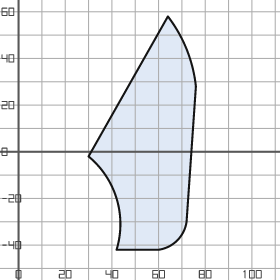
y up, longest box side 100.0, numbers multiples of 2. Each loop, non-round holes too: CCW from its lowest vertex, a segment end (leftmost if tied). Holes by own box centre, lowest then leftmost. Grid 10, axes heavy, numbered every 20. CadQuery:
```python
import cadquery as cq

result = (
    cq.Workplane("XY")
    .moveTo(42.0, -42.0)
    .lineTo(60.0, -42.0)
    .threePointArc((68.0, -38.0), (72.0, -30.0))
    .lineTo(76.0, 28.0)
    .threePointArc((72.0, 44.0), (64.0, 58.0))
    .lineTo(30.0, -2.0)
    .threePointArc((42.0, -20.0), (42.0, -42.0))
    .close()
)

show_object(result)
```